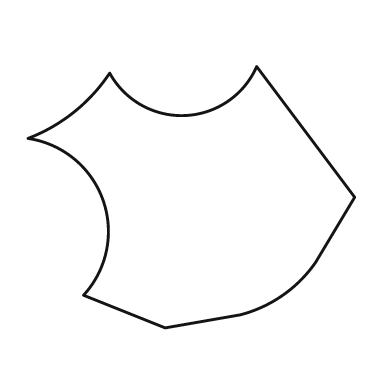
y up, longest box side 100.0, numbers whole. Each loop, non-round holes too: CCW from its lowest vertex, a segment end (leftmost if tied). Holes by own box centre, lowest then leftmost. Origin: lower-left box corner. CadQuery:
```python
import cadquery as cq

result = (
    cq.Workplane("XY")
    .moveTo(42.0, 0.0)
    .lineTo(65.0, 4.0)
    .threePointArc((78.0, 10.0), (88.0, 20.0))
    .lineTo(100.0, 40.0)
    .lineTo(70.0, 80.0)
    .threePointArc((48.0, 65.0), (25.0, 78.0))
    .threePointArc((14.0, 66.0), (0.0, 58.0))
    .threePointArc((23.0, 39.0), (17.0, 10.0))
    .close()
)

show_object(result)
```